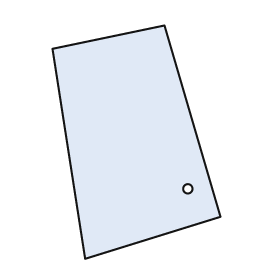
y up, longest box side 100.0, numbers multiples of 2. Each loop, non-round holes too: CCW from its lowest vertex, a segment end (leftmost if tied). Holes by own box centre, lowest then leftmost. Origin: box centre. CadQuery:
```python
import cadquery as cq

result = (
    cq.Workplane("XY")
    .moveTo(-22.0, -50.0)
    .lineTo(36.0, -32.0)
    .lineTo(12.0, 50.0)
    .lineTo(-36.0, 40.0)
    .close()
    .moveTo(22.0, -20.0)
    .circle(2.0)
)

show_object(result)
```